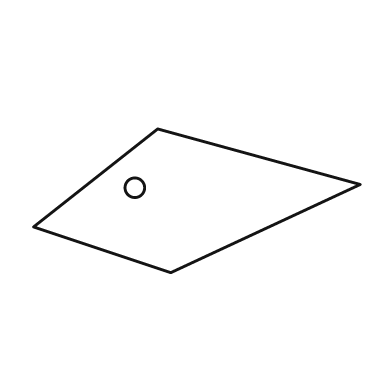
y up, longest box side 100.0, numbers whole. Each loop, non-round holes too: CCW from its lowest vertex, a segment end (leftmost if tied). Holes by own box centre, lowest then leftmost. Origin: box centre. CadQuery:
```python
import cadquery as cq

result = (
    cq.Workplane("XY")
    .moveTo(-8.0, -22.0)
    .lineTo(50.0, 5.0)
    .lineTo(-12.0, 22.0)
    .lineTo(-50.0, -8.0)
    .close()
    .moveTo(-19.0, 4.0)
    .circle(3.0)
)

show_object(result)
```